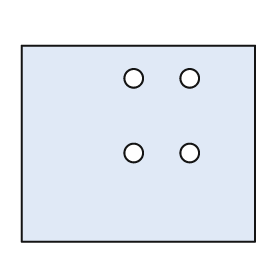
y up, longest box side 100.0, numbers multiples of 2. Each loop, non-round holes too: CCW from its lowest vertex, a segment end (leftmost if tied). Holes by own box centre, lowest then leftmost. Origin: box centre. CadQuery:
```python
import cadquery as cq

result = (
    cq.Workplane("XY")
    .moveTo(-50.0, -42.0)
    .lineTo(50.0, -42.0)
    .lineTo(50.0, 42.0)
    .lineTo(-50.0, 42.0)
    .close()
    .moveTo(-2.0, -4.0)
    .circle(4.0)
    .moveTo(22.0, -4.0)
    .circle(4.0)
    .moveTo(-2.0, 28.0)
    .circle(4.0)
    .moveTo(22.0, 28.0)
    .circle(4.0)
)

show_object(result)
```